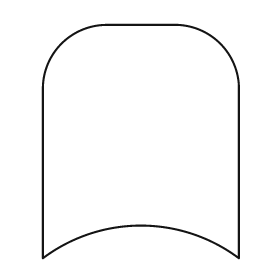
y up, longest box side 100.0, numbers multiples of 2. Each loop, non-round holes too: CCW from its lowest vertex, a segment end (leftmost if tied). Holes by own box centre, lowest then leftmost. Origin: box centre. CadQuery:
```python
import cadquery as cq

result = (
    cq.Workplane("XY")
    .moveTo(-42.0, -50.0)
    .threePointArc((0.0, -36.0), (42.0, -50.0))
    .lineTo(42.0, 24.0)
    .threePointArc((34.0, 42.0), (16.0, 50.0))
    .lineTo(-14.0, 50.0)
    .threePointArc((-34.0, 42.0), (-42.0, 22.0))
    .close()
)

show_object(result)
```